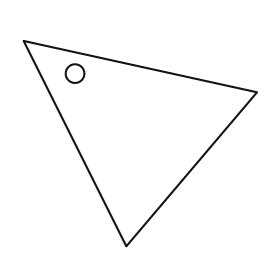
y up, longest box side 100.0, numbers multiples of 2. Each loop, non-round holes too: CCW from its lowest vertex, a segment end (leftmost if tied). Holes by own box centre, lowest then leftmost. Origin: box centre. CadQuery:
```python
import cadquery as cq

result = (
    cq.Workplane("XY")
    .moveTo(-6.0, -44.0)
    .lineTo(50.0, 22.0)
    .lineTo(-50.0, 44.0)
    .close()
    .moveTo(-28.0, 30.0)
    .circle(4.0)
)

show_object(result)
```